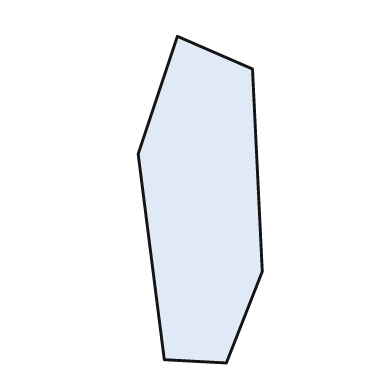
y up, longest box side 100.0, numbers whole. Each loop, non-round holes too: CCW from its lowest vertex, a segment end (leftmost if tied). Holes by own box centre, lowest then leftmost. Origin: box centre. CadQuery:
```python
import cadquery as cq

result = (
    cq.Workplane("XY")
    .moveTo(8.0, -50.0)
    .lineTo(19.0, -22.0)
    .lineTo(16.0, 40.0)
    .lineTo(-7.0, 50.0)
    .lineTo(-19.0, 14.0)
    .lineTo(-11.0, -49.0)
    .close()
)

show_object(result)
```